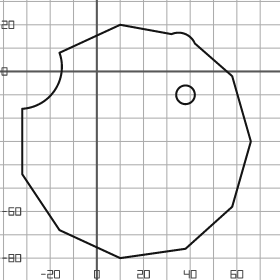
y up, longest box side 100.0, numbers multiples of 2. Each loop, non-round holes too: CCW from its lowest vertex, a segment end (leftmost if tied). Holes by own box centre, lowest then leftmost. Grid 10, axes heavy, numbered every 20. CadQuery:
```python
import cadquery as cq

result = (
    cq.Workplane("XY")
    .moveTo(10.0, -80.0)
    .lineTo(38.0, -76.0)
    .lineTo(58.0, -58.0)
    .lineTo(66.0, -30.0)
    .lineTo(58.0, -2.0)
    .lineTo(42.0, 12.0)
    .threePointArc((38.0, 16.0), (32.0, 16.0))
    .lineTo(10.0, 20.0)
    .lineTo(-16.0, 8.0)
    .threePointArc((-18.0, -8.0), (-32.0, -16.0))
    .lineTo(-32.0, -44.0)
    .lineTo(-16.0, -68.0)
    .close()
    .moveTo(38.0, -10.0)
    .circle(4.0)
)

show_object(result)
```